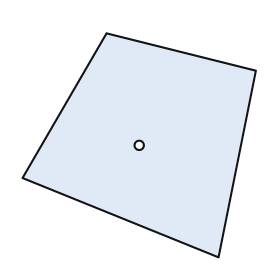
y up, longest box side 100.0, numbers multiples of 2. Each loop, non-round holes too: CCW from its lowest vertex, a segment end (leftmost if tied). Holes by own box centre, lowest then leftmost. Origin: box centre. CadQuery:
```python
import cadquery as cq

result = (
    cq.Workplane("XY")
    .moveTo(34.0, -48.0)
    .lineTo(50.0, 32.0)
    .lineTo(-14.0, 48.0)
    .lineTo(-50.0, -14.0)
    .close()
    .moveTo(0.0, 0.0)
    .circle(2.0)
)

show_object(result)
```